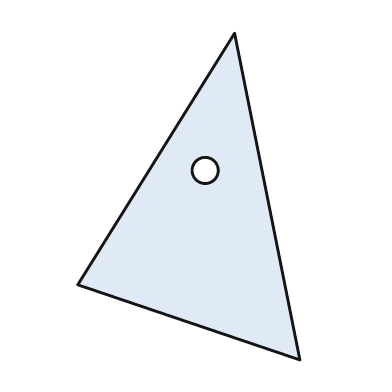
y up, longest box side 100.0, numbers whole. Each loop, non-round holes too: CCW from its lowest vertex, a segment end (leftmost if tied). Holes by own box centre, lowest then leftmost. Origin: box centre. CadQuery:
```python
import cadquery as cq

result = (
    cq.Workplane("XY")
    .moveTo(34.0, -50.0)
    .lineTo(14.0, 50.0)
    .lineTo(-34.0, -27.0)
    .close()
    .moveTo(5.0, 8.0)
    .circle(4.0)
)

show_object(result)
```